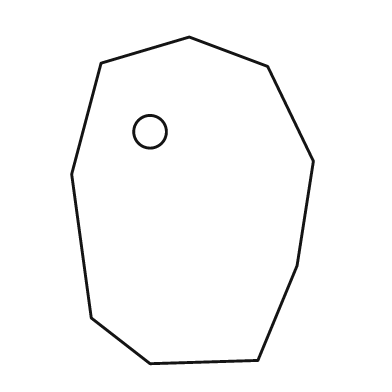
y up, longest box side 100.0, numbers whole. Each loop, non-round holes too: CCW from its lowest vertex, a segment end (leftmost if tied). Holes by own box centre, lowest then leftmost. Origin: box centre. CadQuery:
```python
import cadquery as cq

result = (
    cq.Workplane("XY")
    .moveTo(-13.0, -50.0)
    .lineTo(20.0, -49.0)
    .lineTo(32.0, -20.0)
    .lineTo(37.0, 12.0)
    .lineTo(23.0, 41.0)
    .lineTo(-1.0, 50.0)
    .lineTo(-28.0, 42.0)
    .lineTo(-37.0, 8.0)
    .lineTo(-31.0, -36.0)
    .close()
    .moveTo(-13.0, 21.0)
    .circle(5.0)
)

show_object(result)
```